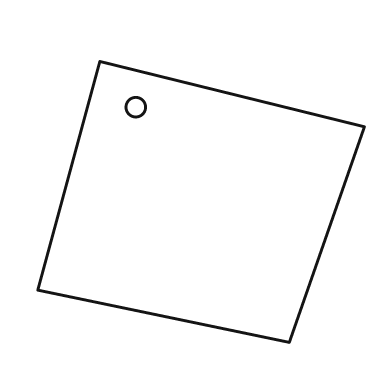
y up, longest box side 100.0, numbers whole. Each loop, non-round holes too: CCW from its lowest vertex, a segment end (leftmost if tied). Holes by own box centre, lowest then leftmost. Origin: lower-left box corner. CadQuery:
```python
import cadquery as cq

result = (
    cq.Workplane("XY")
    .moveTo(77.0, 0.0)
    .lineTo(100.0, 66.0)
    .lineTo(19.0, 86.0)
    .lineTo(0.0, 16.0)
    .close()
    .moveTo(30.0, 72.0)
    .circle(3.0)
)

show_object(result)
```